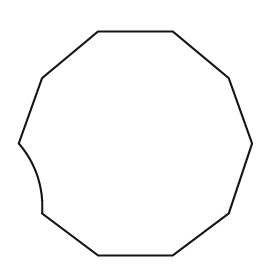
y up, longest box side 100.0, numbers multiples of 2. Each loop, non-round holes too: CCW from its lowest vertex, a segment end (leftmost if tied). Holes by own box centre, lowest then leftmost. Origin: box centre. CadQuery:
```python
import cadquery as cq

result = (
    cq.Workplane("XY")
    .moveTo(-16.0, -48.0)
    .lineTo(16.0, -48.0)
    .lineTo(40.0, -30.0)
    .lineTo(50.0, 0.0)
    .lineTo(40.0, 28.0)
    .lineTo(16.0, 48.0)
    .lineTo(-16.0, 48.0)
    .lineTo(-40.0, 28.0)
    .lineTo(-50.0, 0.0)
    .threePointArc((-42.0, -14.0), (-40.0, -30.0))
    .close()
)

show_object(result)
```